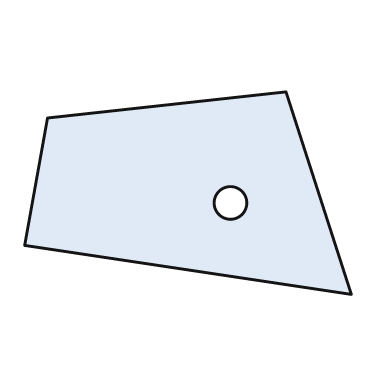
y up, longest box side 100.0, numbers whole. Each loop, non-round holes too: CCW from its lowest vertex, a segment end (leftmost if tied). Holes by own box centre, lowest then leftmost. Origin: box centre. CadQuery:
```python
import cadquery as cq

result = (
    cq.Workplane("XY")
    .moveTo(50.0, -31.0)
    .lineTo(30.0, 31.0)
    .lineTo(-43.0, 23.0)
    .lineTo(-50.0, -16.0)
    .close()
    .moveTo(13.0, -3.0)
    .circle(5.0)
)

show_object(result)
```